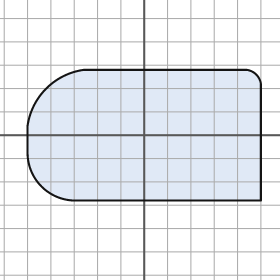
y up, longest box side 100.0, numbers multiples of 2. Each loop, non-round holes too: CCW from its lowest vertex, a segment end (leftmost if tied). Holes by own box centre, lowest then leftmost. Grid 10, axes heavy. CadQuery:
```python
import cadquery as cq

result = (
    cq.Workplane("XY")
    .moveTo(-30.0, -28.0)
    .lineTo(50.0, -28.0)
    .lineTo(50.0, 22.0)
    .threePointArc((48.0, 26.0), (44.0, 28.0))
    .lineTo(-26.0, 28.0)
    .threePointArc((-42.0, 20.0), (-50.0, 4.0))
    .lineTo(-50.0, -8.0)
    .threePointArc((-44.0, -22.0), (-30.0, -28.0))
    .close()
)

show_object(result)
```